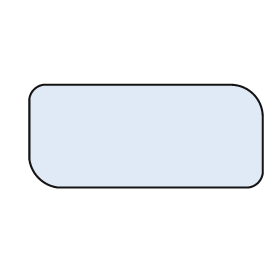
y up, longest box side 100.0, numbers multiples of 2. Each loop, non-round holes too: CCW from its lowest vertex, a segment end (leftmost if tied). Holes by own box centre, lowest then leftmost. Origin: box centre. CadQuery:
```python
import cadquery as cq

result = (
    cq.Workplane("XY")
    .moveTo(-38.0, -22.0)
    .lineTo(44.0, -22.0)
    .threePointArc((48.0, -20.0), (50.0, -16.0))
    .lineTo(50.0, 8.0)
    .threePointArc((46.0, 18.0), (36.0, 22.0))
    .lineTo(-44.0, 22.0)
    .threePointArc((-48.0, 20.0), (-50.0, 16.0))
    .lineTo(-50.0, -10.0)
    .threePointArc((-46.0, -18.0), (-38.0, -22.0))
    .close()
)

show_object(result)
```